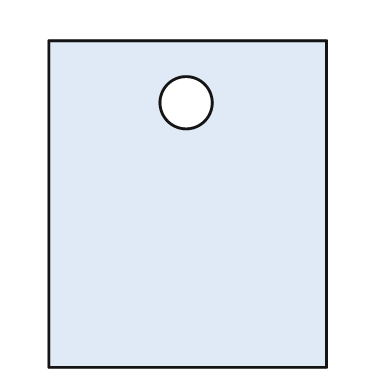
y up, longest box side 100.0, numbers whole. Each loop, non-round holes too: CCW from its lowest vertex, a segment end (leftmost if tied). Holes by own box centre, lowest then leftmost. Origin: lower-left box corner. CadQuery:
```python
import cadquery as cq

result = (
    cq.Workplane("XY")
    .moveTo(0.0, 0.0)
    .lineTo(85.0, 0.0)
    .lineTo(85.0, 100.0)
    .lineTo(0.0, 100.0)
    .close()
    .moveTo(42.0, 81.0)
    .circle(8.0)
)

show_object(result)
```